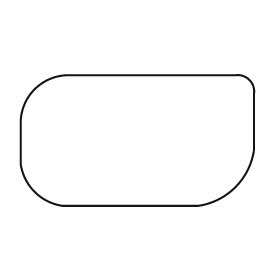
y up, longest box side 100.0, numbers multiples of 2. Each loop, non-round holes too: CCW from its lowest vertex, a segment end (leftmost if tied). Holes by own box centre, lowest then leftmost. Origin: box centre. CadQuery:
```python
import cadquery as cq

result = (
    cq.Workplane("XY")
    .moveTo(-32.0, -28.0)
    .lineTo(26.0, -28.0)
    .threePointArc((42.0, -20.0), (50.0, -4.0))
    .lineTo(50.0, 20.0)
    .threePointArc((48.0, 26.0), (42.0, 28.0))
    .lineTo(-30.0, 28.0)
    .threePointArc((-44.0, 22.0), (-50.0, 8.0))
    .lineTo(-50.0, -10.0)
    .threePointArc((-44.0, -22.0), (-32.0, -28.0))
    .close()
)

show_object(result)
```